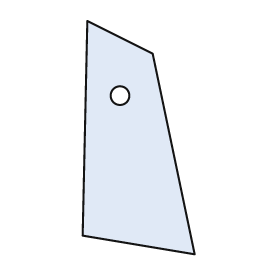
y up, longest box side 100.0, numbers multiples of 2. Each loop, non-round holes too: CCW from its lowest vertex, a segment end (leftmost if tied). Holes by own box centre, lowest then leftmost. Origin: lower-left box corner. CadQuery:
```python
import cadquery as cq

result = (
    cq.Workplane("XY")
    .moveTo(48.0, 0.0)
    .lineTo(30.0, 86.0)
    .lineTo(2.0, 100.0)
    .lineTo(0.0, 8.0)
    .close()
    .moveTo(16.0, 68.0)
    .circle(4.0)
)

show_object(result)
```